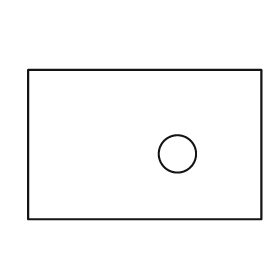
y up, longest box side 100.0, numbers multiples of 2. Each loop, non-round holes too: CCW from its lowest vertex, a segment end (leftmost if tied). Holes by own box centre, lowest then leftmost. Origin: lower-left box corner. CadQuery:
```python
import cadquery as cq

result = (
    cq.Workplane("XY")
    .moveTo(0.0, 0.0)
    .lineTo(100.0, 0.0)
    .lineTo(100.0, 64.0)
    .lineTo(0.0, 64.0)
    .close()
    .moveTo(64.0, 28.0)
    .circle(8.0)
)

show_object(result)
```